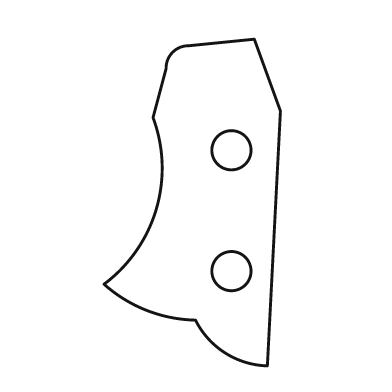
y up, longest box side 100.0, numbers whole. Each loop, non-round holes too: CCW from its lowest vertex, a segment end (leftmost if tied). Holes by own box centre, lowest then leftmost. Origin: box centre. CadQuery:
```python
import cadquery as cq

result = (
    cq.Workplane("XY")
    .moveTo(23.0, -50.0)
    .lineTo(27.0, 28.0)
    .lineTo(19.0, 50.0)
    .lineTo(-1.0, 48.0)
    .threePointArc((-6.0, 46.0), (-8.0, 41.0))
    .lineTo(-12.0, 26.0)
    .threePointArc((-11.0, -2.0), (-27.0, -25.0))
    .threePointArc((-14.0, -33.0), (1.0, -36.0))
    .threePointArc((10.0, -46.0), (23.0, -50.0))
    .close()
    .moveTo(12.0, -21.0)
    .circle(6.0)
    .moveTo(12.0, 16.0)
    .circle(6.0)
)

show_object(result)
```